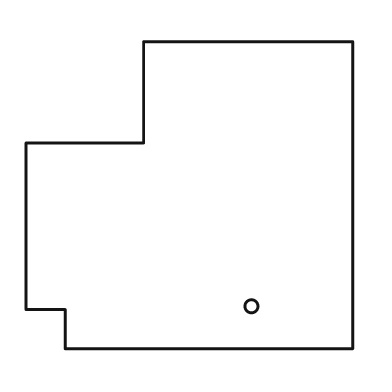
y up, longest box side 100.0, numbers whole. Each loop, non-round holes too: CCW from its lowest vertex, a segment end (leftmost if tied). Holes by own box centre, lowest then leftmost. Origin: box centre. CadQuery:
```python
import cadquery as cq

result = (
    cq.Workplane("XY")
    .moveTo(-38.0, -47.0)
    .lineTo(50.0, -47.0)
    .lineTo(50.0, 47.0)
    .lineTo(-14.0, 47.0)
    .lineTo(-14.0, 16.0)
    .lineTo(-50.0, 16.0)
    .lineTo(-50.0, -35.0)
    .lineTo(-38.0, -35.0)
    .close()
    .moveTo(19.0, -34.0)
    .circle(2.0)
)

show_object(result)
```